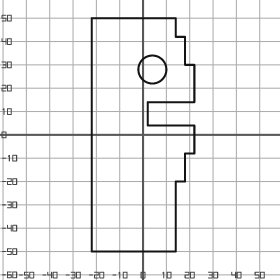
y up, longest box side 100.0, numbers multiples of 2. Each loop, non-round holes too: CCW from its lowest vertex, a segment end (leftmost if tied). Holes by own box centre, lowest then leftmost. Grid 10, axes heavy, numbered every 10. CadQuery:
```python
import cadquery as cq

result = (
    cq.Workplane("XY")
    .moveTo(-22.0, -50.0)
    .lineTo(14.0, -50.0)
    .lineTo(14.0, -20.0)
    .lineTo(18.0, -20.0)
    .lineTo(18.0, -8.0)
    .lineTo(22.0, -8.0)
    .lineTo(22.0, 4.0)
    .lineTo(2.0, 4.0)
    .lineTo(2.0, 14.0)
    .lineTo(22.0, 14.0)
    .lineTo(22.0, 30.0)
    .lineTo(18.0, 30.0)
    .lineTo(18.0, 42.0)
    .lineTo(14.0, 42.0)
    .lineTo(14.0, 50.0)
    .lineTo(-22.0, 50.0)
    .close()
    .moveTo(4.0, 28.0)
    .circle(6.0)
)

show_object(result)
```